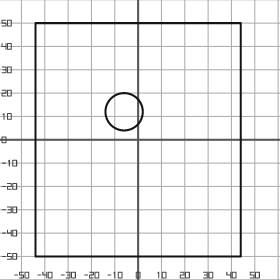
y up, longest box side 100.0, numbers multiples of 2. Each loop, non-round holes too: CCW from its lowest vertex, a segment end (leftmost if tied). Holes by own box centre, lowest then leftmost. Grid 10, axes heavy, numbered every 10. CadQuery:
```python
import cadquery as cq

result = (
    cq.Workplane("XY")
    .moveTo(-44.0, -50.0)
    .lineTo(44.0, -50.0)
    .lineTo(44.0, 50.0)
    .lineTo(-44.0, 50.0)
    .close()
    .moveTo(-6.0, 12.0)
    .circle(8.0)
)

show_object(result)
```